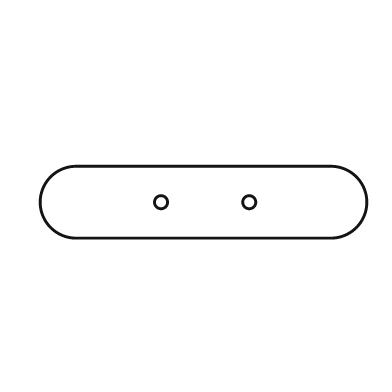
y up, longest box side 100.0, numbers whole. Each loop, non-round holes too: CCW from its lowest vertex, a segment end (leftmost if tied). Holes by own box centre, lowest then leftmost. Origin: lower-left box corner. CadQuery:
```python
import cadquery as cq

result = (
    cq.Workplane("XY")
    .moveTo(11.0, 0.0)
    .lineTo(89.0, 0.0)
    .threePointArc((100.0, 11.0), (89.0, 22.0))
    .lineTo(11.0, 22.0)
    .threePointArc((0.0, 11.0), (11.0, 0.0))
    .close()
    .moveTo(37.0, 11.0)
    .circle(2.0)
    .moveTo(64.0, 11.0)
    .circle(2.0)
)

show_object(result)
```